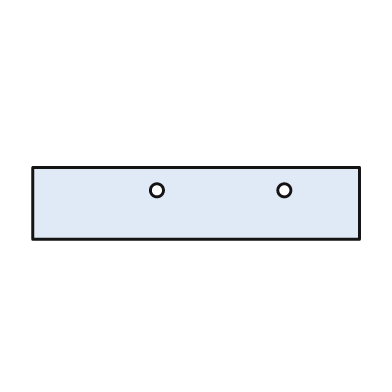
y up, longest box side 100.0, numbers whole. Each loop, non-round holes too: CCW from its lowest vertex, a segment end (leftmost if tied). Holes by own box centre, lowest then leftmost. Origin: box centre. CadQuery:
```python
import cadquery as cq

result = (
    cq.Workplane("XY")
    .moveTo(-50.0, -11.0)
    .lineTo(50.0, -11.0)
    .lineTo(50.0, 11.0)
    .lineTo(-50.0, 11.0)
    .close()
    .moveTo(-12.0, 4.0)
    .circle(2.0)
    .moveTo(27.0, 4.0)
    .circle(2.0)
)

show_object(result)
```